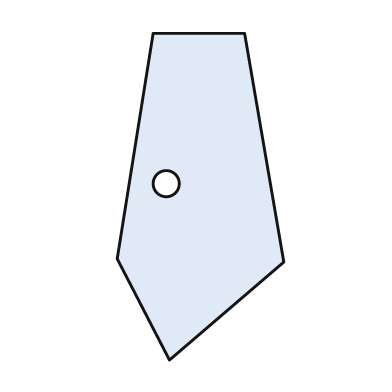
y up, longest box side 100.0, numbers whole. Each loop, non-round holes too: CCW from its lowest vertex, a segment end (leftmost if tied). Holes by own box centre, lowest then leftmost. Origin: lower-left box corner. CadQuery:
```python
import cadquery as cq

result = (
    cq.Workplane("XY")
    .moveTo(16.0, 0.0)
    .lineTo(51.0, 30.0)
    .lineTo(39.0, 100.0)
    .lineTo(11.0, 100.0)
    .lineTo(0.0, 31.0)
    .close()
    .moveTo(15.0, 54.0)
    .circle(4.0)
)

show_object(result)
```